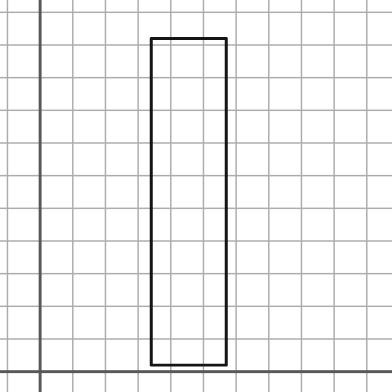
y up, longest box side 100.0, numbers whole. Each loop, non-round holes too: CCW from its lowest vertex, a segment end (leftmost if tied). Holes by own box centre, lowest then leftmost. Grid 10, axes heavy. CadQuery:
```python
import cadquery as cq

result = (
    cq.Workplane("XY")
    .moveTo(34.0, 2.0)
    .lineTo(57.0, 2.0)
    .lineTo(57.0, 102.0)
    .lineTo(34.0, 102.0)
    .close()
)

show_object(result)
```